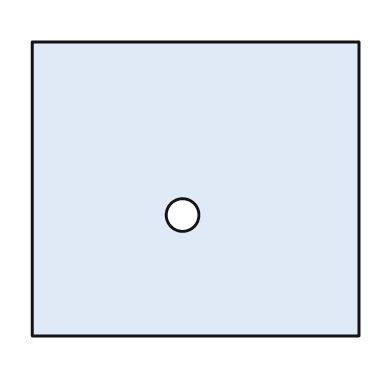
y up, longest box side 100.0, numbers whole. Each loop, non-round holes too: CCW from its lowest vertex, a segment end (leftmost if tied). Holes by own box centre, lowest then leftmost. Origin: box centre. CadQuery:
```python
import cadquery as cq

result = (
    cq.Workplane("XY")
    .moveTo(-50.0, -45.0)
    .lineTo(50.0, -45.0)
    .lineTo(50.0, 45.0)
    .lineTo(-50.0, 45.0)
    .close()
    .moveTo(-4.0, -8.0)
    .circle(5.0)
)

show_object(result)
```